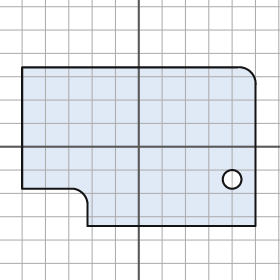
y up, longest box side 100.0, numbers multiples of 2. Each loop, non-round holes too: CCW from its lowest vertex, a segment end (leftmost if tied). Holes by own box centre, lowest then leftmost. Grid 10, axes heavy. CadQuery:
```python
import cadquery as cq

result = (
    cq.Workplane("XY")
    .moveTo(-22.0, -34.0)
    .lineTo(50.0, -34.0)
    .lineTo(50.0, 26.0)
    .threePointArc((48.0, 32.0), (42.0, 34.0))
    .lineTo(-50.0, 34.0)
    .lineTo(-50.0, -18.0)
    .lineTo(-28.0, -18.0)
    .threePointArc((-24.0, -20.0), (-22.0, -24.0))
    .close()
    .moveTo(40.0, -14.0)
    .circle(4.0)
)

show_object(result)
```